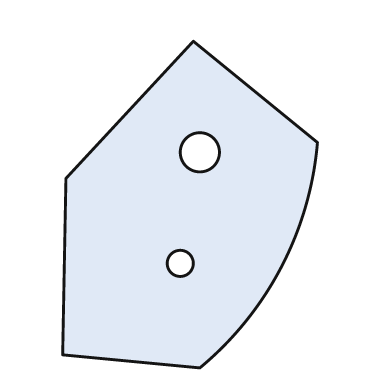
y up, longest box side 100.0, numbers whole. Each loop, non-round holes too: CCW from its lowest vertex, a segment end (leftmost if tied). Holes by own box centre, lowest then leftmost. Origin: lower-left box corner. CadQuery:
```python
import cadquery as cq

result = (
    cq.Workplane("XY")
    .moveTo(42.0, 0.0)
    .threePointArc((67.0, 31.0), (78.0, 69.0))
    .lineTo(40.0, 100.0)
    .lineTo(1.0, 58.0)
    .lineTo(0.0, 4.0)
    .close()
    .moveTo(36.0, 32.0)
    .circle(4.0)
    .moveTo(42.0, 66.0)
    .circle(6.0)
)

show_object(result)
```